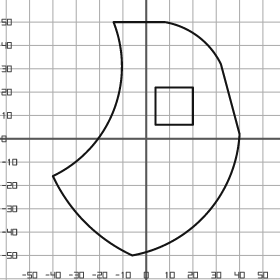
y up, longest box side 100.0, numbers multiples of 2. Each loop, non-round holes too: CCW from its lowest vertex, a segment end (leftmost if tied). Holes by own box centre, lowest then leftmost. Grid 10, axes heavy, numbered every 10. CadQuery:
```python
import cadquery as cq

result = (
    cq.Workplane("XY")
    .moveTo(-6.0, -50.0)
    .threePointArc((26.0, -32.0), (40.0, 2.0))
    .lineTo(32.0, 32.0)
    .threePointArc((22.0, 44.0), (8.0, 50.0))
    .lineTo(-14.0, 50.0)
    .threePointArc((-14.0, 12.0), (-40.0, -16.0))
    .threePointArc((-26.0, -36.0), (-6.0, -50.0))
    .close()
    .moveTo(4.0, 6.0)
    .lineTo(20.0, 6.0)
    .lineTo(20.0, 22.0)
    .lineTo(4.0, 22.0)
    .close()
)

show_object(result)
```